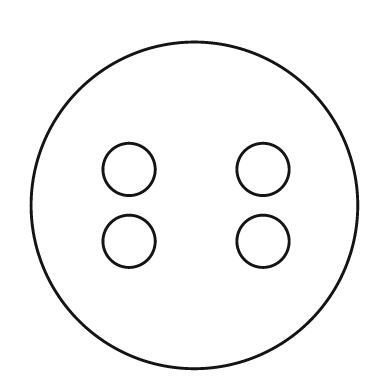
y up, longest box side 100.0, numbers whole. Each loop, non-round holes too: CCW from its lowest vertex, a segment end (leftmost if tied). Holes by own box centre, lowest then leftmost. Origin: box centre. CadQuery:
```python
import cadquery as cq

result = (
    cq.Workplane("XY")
    .moveTo(0.0, 0.0)
    .circle(50.0)
    .moveTo(-20.0, -11.0)
    .circle(8.0)
    .moveTo(21.0, -11.0)
    .circle(8.0)
    .moveTo(-20.0, 11.0)
    .circle(8.0)
    .moveTo(21.0, 11.0)
    .circle(8.0)
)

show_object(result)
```